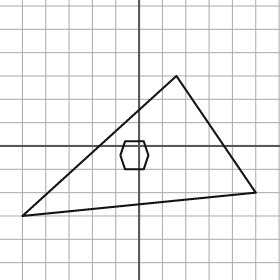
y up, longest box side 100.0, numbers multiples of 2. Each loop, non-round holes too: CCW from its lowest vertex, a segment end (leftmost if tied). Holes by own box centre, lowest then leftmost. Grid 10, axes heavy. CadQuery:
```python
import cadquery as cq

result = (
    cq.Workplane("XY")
    .moveTo(-50.0, -30.0)
    .lineTo(50.0, -20.0)
    .lineTo(16.0, 30.0)
    .close()
    .moveTo(-6.0, -10.0)
    .lineTo(2.0, -10.0)
    .lineTo(4.0, -4.0)
    .lineTo(2.0, 2.0)
    .lineTo(-6.0, 2.0)
    .lineTo(-8.0, -4.0)
    .close()
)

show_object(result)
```